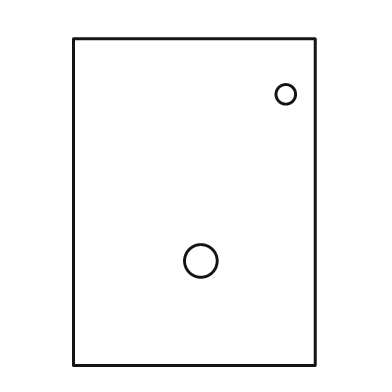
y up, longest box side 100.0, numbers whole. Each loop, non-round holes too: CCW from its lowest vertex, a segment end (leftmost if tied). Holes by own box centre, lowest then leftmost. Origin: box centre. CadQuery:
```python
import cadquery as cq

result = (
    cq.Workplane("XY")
    .moveTo(-37.0, -50.0)
    .lineTo(37.0, -50.0)
    .lineTo(37.0, 50.0)
    .lineTo(-37.0, 50.0)
    .close()
    .moveTo(2.0, -18.0)
    .circle(5.0)
    .moveTo(28.0, 33.0)
    .circle(3.0)
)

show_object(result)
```